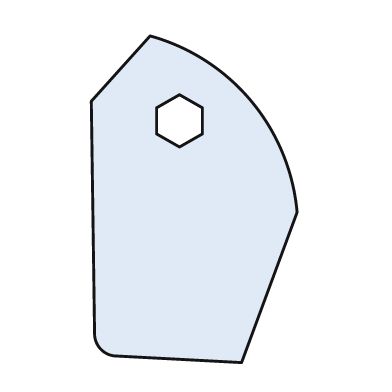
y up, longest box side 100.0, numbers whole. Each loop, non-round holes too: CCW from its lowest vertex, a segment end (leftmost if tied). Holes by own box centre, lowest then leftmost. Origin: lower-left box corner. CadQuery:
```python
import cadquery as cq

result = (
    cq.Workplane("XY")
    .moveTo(46.0, 0.0)
    .lineTo(63.0, 46.0)
    .threePointArc((49.0, 80.0), (18.0, 100.0))
    .lineTo(0.0, 80.0)
    .lineTo(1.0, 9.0)
    .threePointArc((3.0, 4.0), (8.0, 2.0))
    .close()
    .moveTo(27.0, 66.0)
    .lineTo(34.0, 70.0)
    .lineTo(34.0, 78.0)
    .lineTo(27.0, 82.0)
    .lineTo(20.0, 78.0)
    .lineTo(20.0, 70.0)
    .close()
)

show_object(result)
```